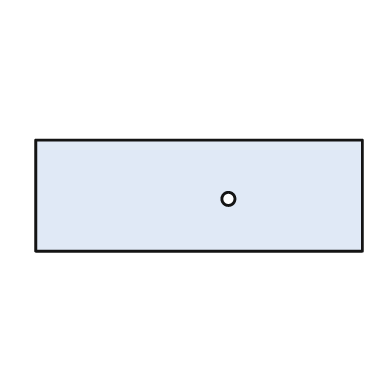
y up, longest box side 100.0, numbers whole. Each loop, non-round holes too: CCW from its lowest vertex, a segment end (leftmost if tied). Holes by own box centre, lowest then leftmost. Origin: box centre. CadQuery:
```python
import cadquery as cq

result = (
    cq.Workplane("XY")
    .moveTo(-50.0, -17.0)
    .lineTo(50.0, -17.0)
    .lineTo(50.0, 17.0)
    .lineTo(-50.0, 17.0)
    .close()
    .moveTo(9.0, -1.0)
    .circle(2.0)
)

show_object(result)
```